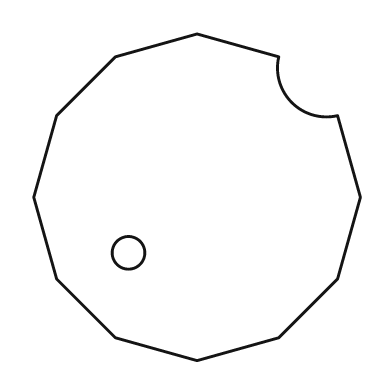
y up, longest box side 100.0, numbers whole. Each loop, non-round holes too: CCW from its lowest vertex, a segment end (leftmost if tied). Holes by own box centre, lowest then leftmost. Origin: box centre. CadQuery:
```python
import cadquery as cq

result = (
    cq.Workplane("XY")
    .moveTo(0.0, -50.0)
    .lineTo(25.0, -43.0)
    .lineTo(43.0, -25.0)
    .lineTo(50.0, 0.0)
    .lineTo(43.0, 25.0)
    .threePointArc((29.0, 29.0), (25.0, 43.0))
    .lineTo(0.0, 50.0)
    .lineTo(-25.0, 43.0)
    .lineTo(-43.0, 25.0)
    .lineTo(-50.0, 0.0)
    .lineTo(-43.0, -25.0)
    .lineTo(-25.0, -43.0)
    .close()
    .moveTo(-21.0, -17.0)
    .circle(5.0)
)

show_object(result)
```